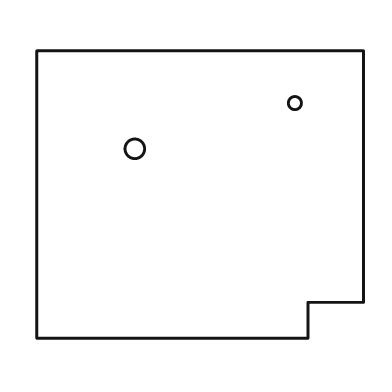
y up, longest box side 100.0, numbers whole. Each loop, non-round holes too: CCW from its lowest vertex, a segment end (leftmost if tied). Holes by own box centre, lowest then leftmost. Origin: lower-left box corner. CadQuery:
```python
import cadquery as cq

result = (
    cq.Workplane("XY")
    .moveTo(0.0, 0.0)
    .lineTo(83.0, 0.0)
    .lineTo(83.0, 11.0)
    .lineTo(100.0, 11.0)
    .lineTo(100.0, 88.0)
    .lineTo(0.0, 88.0)
    .close()
    .moveTo(30.0, 58.0)
    .circle(3.0)
    .moveTo(79.0, 72.0)
    .circle(2.0)
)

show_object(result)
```